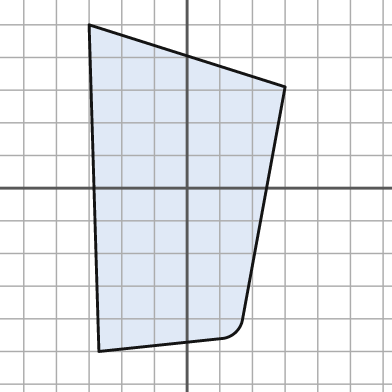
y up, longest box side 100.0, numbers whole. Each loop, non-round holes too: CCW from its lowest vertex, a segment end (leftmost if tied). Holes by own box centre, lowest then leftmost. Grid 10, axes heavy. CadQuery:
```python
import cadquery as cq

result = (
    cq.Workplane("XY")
    .moveTo(-27.0, -50.0)
    .lineTo(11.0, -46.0)
    .threePointArc((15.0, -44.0), (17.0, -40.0))
    .lineTo(30.0, 31.0)
    .lineTo(-30.0, 50.0)
    .close()
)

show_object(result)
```